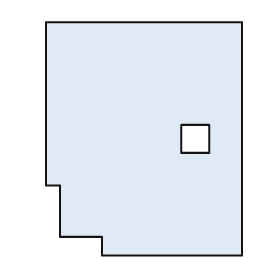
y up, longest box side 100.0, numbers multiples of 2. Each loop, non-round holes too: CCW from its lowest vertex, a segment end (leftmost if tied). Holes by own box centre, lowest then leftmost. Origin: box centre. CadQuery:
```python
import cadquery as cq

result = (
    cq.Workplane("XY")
    .moveTo(-18.0, -50.0)
    .lineTo(42.0, -50.0)
    .lineTo(42.0, 50.0)
    .lineTo(-42.0, 50.0)
    .lineTo(-42.0, -20.0)
    .lineTo(-36.0, -20.0)
    .lineTo(-36.0, -42.0)
    .lineTo(-18.0, -42.0)
    .close()
    .moveTo(16.0, -6.0)
    .lineTo(28.0, -6.0)
    .lineTo(28.0, 6.0)
    .lineTo(16.0, 6.0)
    .close()
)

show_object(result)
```